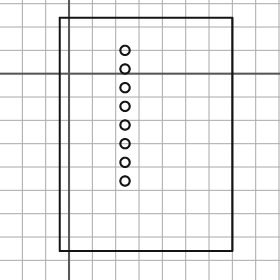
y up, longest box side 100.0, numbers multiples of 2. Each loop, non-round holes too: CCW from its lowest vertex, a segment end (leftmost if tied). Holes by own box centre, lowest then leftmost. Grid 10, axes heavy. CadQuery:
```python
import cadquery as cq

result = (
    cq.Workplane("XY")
    .moveTo(-4.0, -76.0)
    .lineTo(70.0, -76.0)
    .lineTo(70.0, 24.0)
    .lineTo(-4.0, 24.0)
    .close()
    .moveTo(24.0, -46.0)
    .circle(2.0)
    .moveTo(24.0, -38.0)
    .circle(2.0)
    .moveTo(24.0, -30.0)
    .circle(2.0)
    .moveTo(24.0, -22.0)
    .circle(2.0)
    .moveTo(24.0, -14.0)
    .circle(2.0)
    .moveTo(24.0, -6.0)
    .circle(2.0)
    .moveTo(24.0, 2.0)
    .circle(2.0)
    .moveTo(24.0, 10.0)
    .circle(2.0)
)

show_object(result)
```